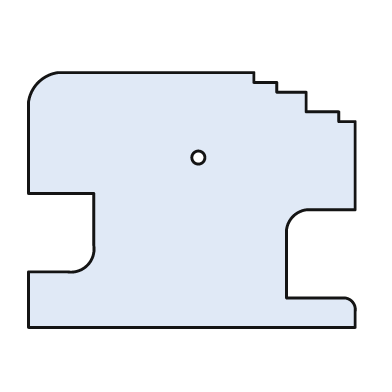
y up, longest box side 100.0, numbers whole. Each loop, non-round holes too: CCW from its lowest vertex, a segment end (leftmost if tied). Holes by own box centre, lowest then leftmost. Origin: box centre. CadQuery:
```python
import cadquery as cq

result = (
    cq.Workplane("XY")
    .moveTo(-50.0, -39.0)
    .lineTo(50.0, -39.0)
    .lineTo(50.0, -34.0)
    .threePointArc((49.0, -31.0), (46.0, -30.0))
    .lineTo(29.0, -30.0)
    .lineTo(29.0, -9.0)
    .threePointArc((31.0, -5.0), (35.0, -3.0))
    .lineTo(50.0, -3.0)
    .lineTo(50.0, 24.0)
    .lineTo(45.0, 24.0)
    .lineTo(45.0, 27.0)
    .lineTo(35.0, 27.0)
    .lineTo(35.0, 33.0)
    .lineTo(26.0, 33.0)
    .lineTo(26.0, 36.0)
    .lineTo(19.0, 36.0)
    .lineTo(19.0, 39.0)
    .lineTo(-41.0, 39.0)
    .threePointArc((-47.0, 36.0), (-50.0, 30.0))
    .lineTo(-50.0, 2.0)
    .lineTo(-30.0, 2.0)
    .lineTo(-30.0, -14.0)
    .threePointArc((-32.0, -20.0), (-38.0, -22.0))
    .lineTo(-50.0, -22.0)
    .close()
    .moveTo(2.0, 13.0)
    .circle(2.0)
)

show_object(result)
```